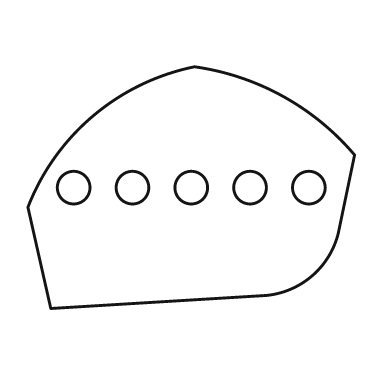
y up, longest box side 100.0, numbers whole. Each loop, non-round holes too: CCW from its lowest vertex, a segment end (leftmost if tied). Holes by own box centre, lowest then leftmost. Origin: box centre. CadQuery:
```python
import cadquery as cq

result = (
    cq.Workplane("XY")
    .moveTo(-43.0, -37.0)
    .lineTo(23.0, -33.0)
    .threePointArc((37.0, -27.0), (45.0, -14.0))
    .lineTo(50.0, 10.0)
    .threePointArc((28.0, 28.0), (1.0, 37.0))
    .threePointArc((-30.0, 22.0), (-50.0, -6.0))
    .close()
    .moveTo(-36.0, 0.0)
    .circle(5.0)
    .moveTo(-18.0, 0.0)
    .circle(5.0)
    .moveTo(0.0, 0.0)
    .circle(5.0)
    .moveTo(18.0, 0.0)
    .circle(5.0)
    .moveTo(36.0, 0.0)
    .circle(5.0)
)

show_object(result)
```